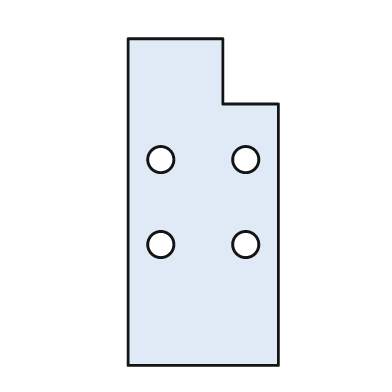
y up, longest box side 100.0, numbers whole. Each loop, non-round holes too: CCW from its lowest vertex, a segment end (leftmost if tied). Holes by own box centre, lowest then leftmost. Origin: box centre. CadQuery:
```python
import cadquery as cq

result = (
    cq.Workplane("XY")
    .moveTo(-23.0, -50.0)
    .lineTo(23.0, -50.0)
    .lineTo(23.0, 30.0)
    .lineTo(6.0, 30.0)
    .lineTo(6.0, 50.0)
    .lineTo(-23.0, 50.0)
    .close()
    .moveTo(-13.0, -13.0)
    .circle(4.0)
    .moveTo(13.0, -13.0)
    .circle(4.0)
    .moveTo(-13.0, 13.0)
    .circle(4.0)
    .moveTo(13.0, 13.0)
    .circle(4.0)
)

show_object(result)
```